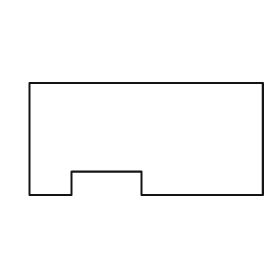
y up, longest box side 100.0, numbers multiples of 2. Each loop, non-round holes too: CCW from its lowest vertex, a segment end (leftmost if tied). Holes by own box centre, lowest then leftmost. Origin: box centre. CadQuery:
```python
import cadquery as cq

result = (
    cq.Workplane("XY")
    .moveTo(-50.0, -24.0)
    .lineTo(-32.0, -24.0)
    .lineTo(-32.0, -14.0)
    .lineTo(-2.0, -14.0)
    .lineTo(-2.0, -24.0)
    .lineTo(50.0, -24.0)
    .lineTo(50.0, 24.0)
    .lineTo(-50.0, 24.0)
    .close()
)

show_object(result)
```